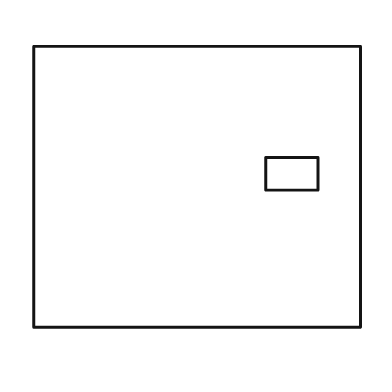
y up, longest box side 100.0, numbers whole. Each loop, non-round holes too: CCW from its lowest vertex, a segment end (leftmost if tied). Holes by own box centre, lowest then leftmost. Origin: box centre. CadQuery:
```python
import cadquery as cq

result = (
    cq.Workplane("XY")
    .moveTo(-50.0, -43.0)
    .lineTo(50.0, -43.0)
    .lineTo(50.0, 43.0)
    .lineTo(-50.0, 43.0)
    .close()
    .moveTo(21.0, -1.0)
    .lineTo(37.0, -1.0)
    .lineTo(37.0, 9.0)
    .lineTo(21.0, 9.0)
    .close()
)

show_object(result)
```